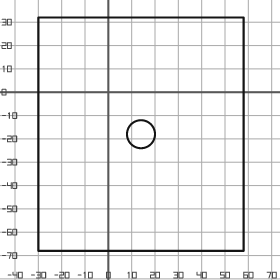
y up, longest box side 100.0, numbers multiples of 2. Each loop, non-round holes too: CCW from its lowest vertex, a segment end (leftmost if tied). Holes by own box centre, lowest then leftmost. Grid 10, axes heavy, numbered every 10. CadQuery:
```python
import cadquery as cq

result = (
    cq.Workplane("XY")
    .moveTo(-30.0, -68.0)
    .lineTo(58.0, -68.0)
    .lineTo(58.0, 32.0)
    .lineTo(-30.0, 32.0)
    .close()
    .moveTo(14.0, -18.0)
    .circle(6.0)
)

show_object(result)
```